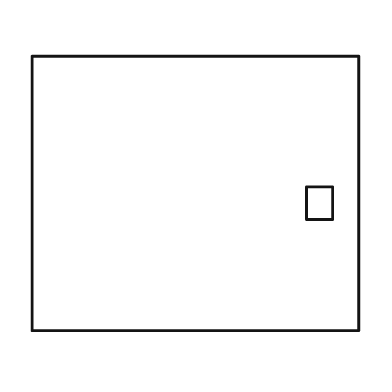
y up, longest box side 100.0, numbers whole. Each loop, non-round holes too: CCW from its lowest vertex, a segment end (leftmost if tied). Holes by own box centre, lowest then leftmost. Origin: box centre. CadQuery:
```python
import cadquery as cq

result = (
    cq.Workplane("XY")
    .moveTo(-50.0, -42.0)
    .lineTo(50.0, -42.0)
    .lineTo(50.0, 42.0)
    .lineTo(-50.0, 42.0)
    .close()
    .moveTo(34.0, -8.0)
    .lineTo(42.0, -8.0)
    .lineTo(42.0, 2.0)
    .lineTo(34.0, 2.0)
    .close()
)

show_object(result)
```